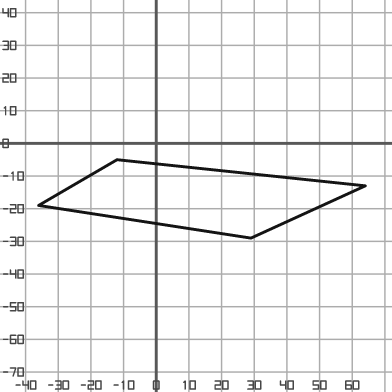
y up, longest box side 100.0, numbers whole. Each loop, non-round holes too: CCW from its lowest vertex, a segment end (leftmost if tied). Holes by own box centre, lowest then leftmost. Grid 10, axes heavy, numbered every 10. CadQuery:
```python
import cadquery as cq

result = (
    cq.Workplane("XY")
    .moveTo(29.0, -29.0)
    .lineTo(64.0, -13.0)
    .lineTo(-12.0, -5.0)
    .lineTo(-36.0, -19.0)
    .close()
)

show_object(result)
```